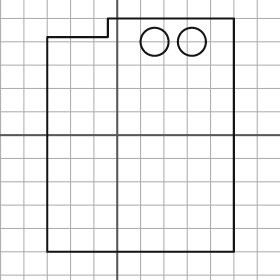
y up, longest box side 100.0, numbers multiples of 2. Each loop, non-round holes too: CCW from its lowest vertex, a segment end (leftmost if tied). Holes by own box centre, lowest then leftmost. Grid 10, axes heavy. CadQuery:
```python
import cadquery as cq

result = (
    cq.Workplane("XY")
    .moveTo(-30.0, -50.0)
    .lineTo(50.0, -50.0)
    .lineTo(50.0, 50.0)
    .lineTo(-4.0, 50.0)
    .lineTo(-4.0, 42.0)
    .lineTo(-30.0, 42.0)
    .close()
    .moveTo(16.0, 40.0)
    .circle(6.0)
    .moveTo(32.0, 40.0)
    .circle(6.0)
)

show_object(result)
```